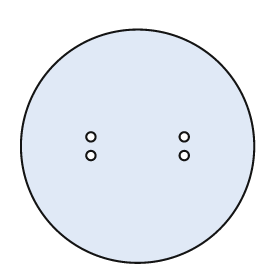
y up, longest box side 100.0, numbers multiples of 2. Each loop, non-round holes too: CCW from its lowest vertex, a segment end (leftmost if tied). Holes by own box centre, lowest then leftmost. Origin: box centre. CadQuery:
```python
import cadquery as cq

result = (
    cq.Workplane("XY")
    .moveTo(0.0, 0.0)
    .circle(50.0)
    .moveTo(-20.0, -4.0)
    .circle(2.0)
    .moveTo(20.0, -4.0)
    .circle(2.0)
    .moveTo(-20.0, 4.0)
    .circle(2.0)
    .moveTo(20.0, 4.0)
    .circle(2.0)
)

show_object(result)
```